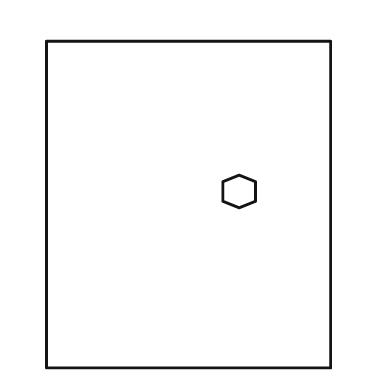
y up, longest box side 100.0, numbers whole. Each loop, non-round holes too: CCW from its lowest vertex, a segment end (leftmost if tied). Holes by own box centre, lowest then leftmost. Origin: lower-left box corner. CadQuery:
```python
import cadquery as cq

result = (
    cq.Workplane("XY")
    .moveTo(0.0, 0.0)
    .lineTo(87.0, 0.0)
    .lineTo(87.0, 100.0)
    .lineTo(0.0, 100.0)
    .close()
    .moveTo(59.0, 49.0)
    .lineTo(64.0, 51.0)
    .lineTo(64.0, 57.0)
    .lineTo(59.0, 59.0)
    .lineTo(54.0, 57.0)
    .lineTo(54.0, 51.0)
    .close()
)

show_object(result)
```